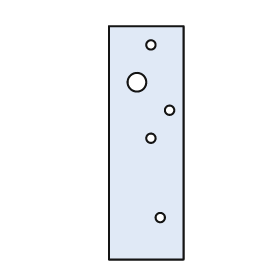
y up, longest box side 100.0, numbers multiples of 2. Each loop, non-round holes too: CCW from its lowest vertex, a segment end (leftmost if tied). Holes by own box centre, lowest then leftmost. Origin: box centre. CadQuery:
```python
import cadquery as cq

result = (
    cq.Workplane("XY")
    .moveTo(-16.0, -50.0)
    .lineTo(16.0, -50.0)
    .lineTo(16.0, 50.0)
    .lineTo(-16.0, 50.0)
    .close()
    .moveTo(6.0, -32.0)
    .circle(2.0)
    .moveTo(2.0, 2.0)
    .circle(2.0)
    .moveTo(10.0, 14.0)
    .circle(2.0)
    .moveTo(-4.0, 26.0)
    .circle(4.0)
    .moveTo(2.0, 42.0)
    .circle(2.0)
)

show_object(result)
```